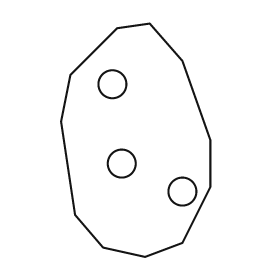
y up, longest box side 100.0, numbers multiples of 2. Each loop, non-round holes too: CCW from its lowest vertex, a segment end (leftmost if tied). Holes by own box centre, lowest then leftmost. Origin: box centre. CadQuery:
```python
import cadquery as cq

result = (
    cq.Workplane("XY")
    .moveTo(4.0, -50.0)
    .lineTo(20.0, -44.0)
    .lineTo(32.0, -20.0)
    .lineTo(32.0, 0.0)
    .lineTo(20.0, 34.0)
    .lineTo(6.0, 50.0)
    .lineTo(-8.0, 48.0)
    .lineTo(-28.0, 28.0)
    .lineTo(-32.0, 8.0)
    .lineTo(-26.0, -32.0)
    .lineTo(-14.0, -46.0)
    .close()
    .moveTo(20.0, -22.0)
    .circle(6.0)
    .moveTo(-6.0, -10.0)
    .circle(6.0)
    .moveTo(-10.0, 24.0)
    .circle(6.0)
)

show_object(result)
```